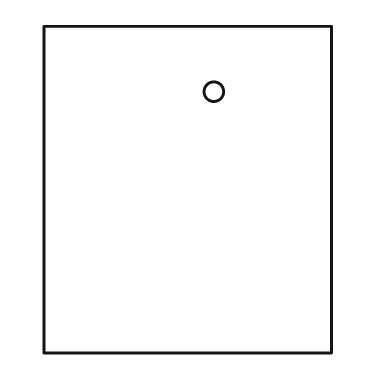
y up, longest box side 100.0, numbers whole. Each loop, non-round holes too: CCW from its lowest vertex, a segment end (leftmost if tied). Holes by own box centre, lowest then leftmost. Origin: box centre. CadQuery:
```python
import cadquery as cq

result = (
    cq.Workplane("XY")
    .moveTo(-44.0, -50.0)
    .lineTo(44.0, -50.0)
    .lineTo(44.0, 50.0)
    .lineTo(-44.0, 50.0)
    .close()
    .moveTo(8.0, 30.0)
    .circle(3.0)
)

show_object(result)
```